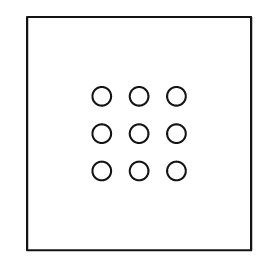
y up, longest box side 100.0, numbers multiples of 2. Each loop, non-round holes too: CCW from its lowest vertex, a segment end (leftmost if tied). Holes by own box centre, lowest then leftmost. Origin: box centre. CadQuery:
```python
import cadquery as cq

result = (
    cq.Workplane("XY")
    .moveTo(-48.0, -50.0)
    .lineTo(48.0, -50.0)
    .lineTo(48.0, 50.0)
    .lineTo(-48.0, 50.0)
    .close()
    .moveTo(-16.0, -16.0)
    .circle(4.0)
    .moveTo(0.0, -16.0)
    .circle(4.0)
    .moveTo(16.0, -16.0)
    .circle(4.0)
    .moveTo(-16.0, 0.0)
    .circle(4.0)
    .moveTo(0.0, 0.0)
    .circle(4.0)
    .moveTo(16.0, 0.0)
    .circle(4.0)
    .moveTo(-16.0, 16.0)
    .circle(4.0)
    .moveTo(0.0, 16.0)
    .circle(4.0)
    .moveTo(16.0, 16.0)
    .circle(4.0)
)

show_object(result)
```